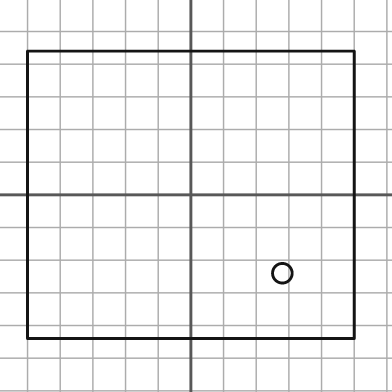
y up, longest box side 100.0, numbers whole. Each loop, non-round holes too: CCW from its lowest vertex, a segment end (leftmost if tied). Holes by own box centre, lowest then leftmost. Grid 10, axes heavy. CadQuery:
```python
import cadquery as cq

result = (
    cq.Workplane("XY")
    .moveTo(-50.0, -44.0)
    .lineTo(50.0, -44.0)
    .lineTo(50.0, 44.0)
    .lineTo(-50.0, 44.0)
    .close()
    .moveTo(28.0, -24.0)
    .circle(3.0)
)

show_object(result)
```